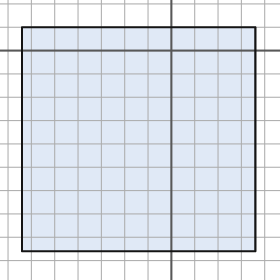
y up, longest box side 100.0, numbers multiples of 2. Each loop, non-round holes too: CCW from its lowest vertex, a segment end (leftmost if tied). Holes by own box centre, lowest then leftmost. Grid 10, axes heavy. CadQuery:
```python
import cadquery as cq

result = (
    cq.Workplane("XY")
    .moveTo(-64.0, -86.0)
    .lineTo(36.0, -86.0)
    .lineTo(36.0, 10.0)
    .lineTo(-64.0, 10.0)
    .close()
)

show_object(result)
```